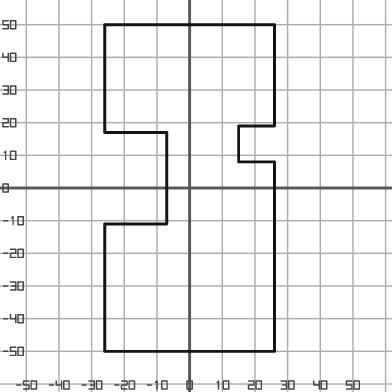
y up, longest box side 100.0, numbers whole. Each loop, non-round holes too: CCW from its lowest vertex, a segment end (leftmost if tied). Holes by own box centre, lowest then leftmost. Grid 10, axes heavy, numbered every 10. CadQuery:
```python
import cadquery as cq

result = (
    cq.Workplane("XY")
    .moveTo(-26.0, -50.0)
    .lineTo(26.0, -50.0)
    .lineTo(26.0, 8.0)
    .lineTo(15.0, 8.0)
    .lineTo(15.0, 19.0)
    .lineTo(26.0, 19.0)
    .lineTo(26.0, 50.0)
    .lineTo(-26.0, 50.0)
    .lineTo(-26.0, 17.0)
    .lineTo(-7.0, 17.0)
    .lineTo(-7.0, -11.0)
    .lineTo(-26.0, -11.0)
    .close()
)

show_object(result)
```